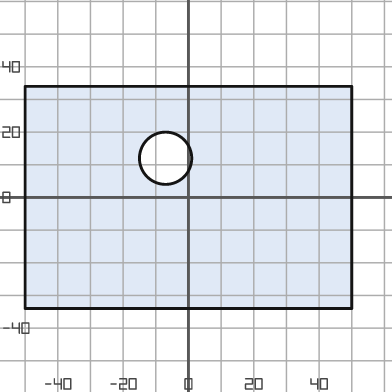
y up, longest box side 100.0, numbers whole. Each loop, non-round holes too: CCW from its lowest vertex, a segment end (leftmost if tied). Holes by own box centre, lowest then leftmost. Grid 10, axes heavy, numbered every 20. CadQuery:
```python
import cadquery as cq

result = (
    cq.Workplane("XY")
    .moveTo(-50.0, -34.0)
    .lineTo(50.0, -34.0)
    .lineTo(50.0, 34.0)
    .lineTo(-50.0, 34.0)
    .close()
    .moveTo(-7.0, 12.0)
    .circle(8.0)
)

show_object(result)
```